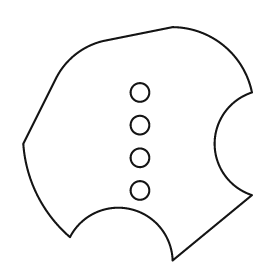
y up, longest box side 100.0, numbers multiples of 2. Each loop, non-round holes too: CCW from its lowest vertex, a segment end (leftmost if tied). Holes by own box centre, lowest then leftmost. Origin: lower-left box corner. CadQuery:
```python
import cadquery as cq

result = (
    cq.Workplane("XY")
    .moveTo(64.0, 0.0)
    .lineTo(98.0, 28.0)
    .threePointArc((82.0, 50.0), (98.0, 72.0))
    .threePointArc((86.0, 92.0), (64.0, 100.0))
    .lineTo(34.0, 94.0)
    .threePointArc((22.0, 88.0), (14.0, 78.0))
    .lineTo(0.0, 50.0)
    .threePointArc((6.0, 28.0), (20.0, 10.0))
    .threePointArc((46.0, 22.0), (64.0, 0.0))
    .close()
    .moveTo(50.0, 30.0)
    .circle(4.0)
    .moveTo(50.0, 44.0)
    .circle(4.0)
    .moveTo(50.0, 58.0)
    .circle(4.0)
    .moveTo(50.0, 72.0)
    .circle(4.0)
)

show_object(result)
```